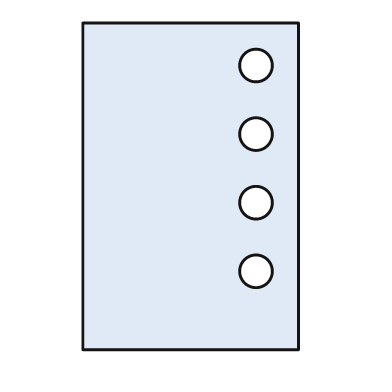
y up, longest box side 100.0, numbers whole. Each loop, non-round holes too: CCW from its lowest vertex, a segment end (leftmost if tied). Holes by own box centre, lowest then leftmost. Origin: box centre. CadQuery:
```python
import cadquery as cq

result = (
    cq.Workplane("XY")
    .moveTo(-33.0, -50.0)
    .lineTo(33.0, -50.0)
    .lineTo(33.0, 50.0)
    .lineTo(-33.0, 50.0)
    .close()
    .moveTo(20.0, -26.0)
    .circle(5.0)
    .moveTo(20.0, -5.0)
    .circle(5.0)
    .moveTo(20.0, 16.0)
    .circle(5.0)
    .moveTo(20.0, 37.0)
    .circle(5.0)
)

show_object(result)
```